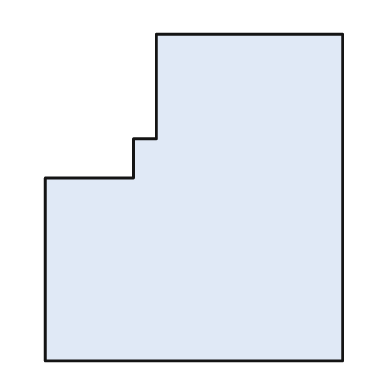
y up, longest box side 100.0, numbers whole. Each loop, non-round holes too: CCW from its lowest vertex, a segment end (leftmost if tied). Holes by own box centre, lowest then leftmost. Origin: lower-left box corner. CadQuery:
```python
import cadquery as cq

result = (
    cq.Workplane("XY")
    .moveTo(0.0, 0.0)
    .lineTo(91.0, 0.0)
    .lineTo(91.0, 100.0)
    .lineTo(34.0, 100.0)
    .lineTo(34.0, 68.0)
    .lineTo(27.0, 68.0)
    .lineTo(27.0, 56.0)
    .lineTo(0.0, 56.0)
    .close()
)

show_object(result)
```